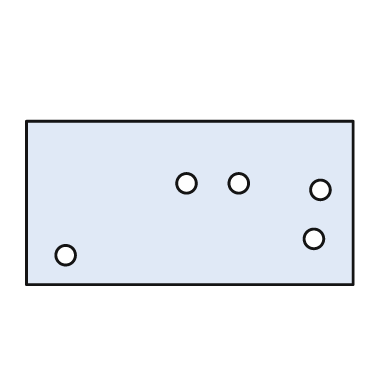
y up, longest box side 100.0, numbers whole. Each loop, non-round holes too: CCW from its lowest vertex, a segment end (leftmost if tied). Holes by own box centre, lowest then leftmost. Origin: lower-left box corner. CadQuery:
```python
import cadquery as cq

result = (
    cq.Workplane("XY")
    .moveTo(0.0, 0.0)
    .lineTo(100.0, 0.0)
    .lineTo(100.0, 50.0)
    .lineTo(0.0, 50.0)
    .close()
    .moveTo(12.0, 9.0)
    .circle(3.0)
    .moveTo(88.0, 14.0)
    .circle(3.0)
    .moveTo(90.0, 29.0)
    .circle(3.0)
    .moveTo(49.0, 31.0)
    .circle(3.0)
    .moveTo(65.0, 31.0)
    .circle(3.0)
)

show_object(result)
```